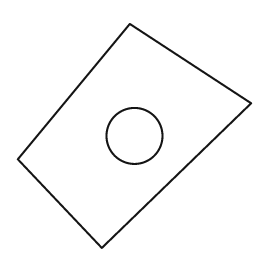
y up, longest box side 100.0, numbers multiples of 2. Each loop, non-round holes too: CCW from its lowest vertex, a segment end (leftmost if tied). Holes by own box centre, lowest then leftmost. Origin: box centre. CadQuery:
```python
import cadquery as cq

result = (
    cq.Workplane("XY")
    .moveTo(-14.0, -48.0)
    .lineTo(50.0, 14.0)
    .lineTo(-2.0, 48.0)
    .lineTo(-50.0, -10.0)
    .close()
    .moveTo(0.0, 0.0)
    .circle(12.0)
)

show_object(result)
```